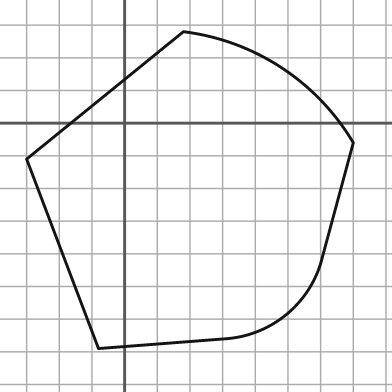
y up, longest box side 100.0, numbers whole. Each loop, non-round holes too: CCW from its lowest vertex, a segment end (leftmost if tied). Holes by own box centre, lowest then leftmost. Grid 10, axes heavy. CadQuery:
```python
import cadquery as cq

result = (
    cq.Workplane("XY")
    .moveTo(-8.0, -69.0)
    .lineTo(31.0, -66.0)
    .threePointArc((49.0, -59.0), (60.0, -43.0))
    .lineTo(70.0, -6.0)
    .threePointArc((48.0, 17.0), (18.0, 28.0))
    .lineTo(-30.0, -11.0)
    .close()
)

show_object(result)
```